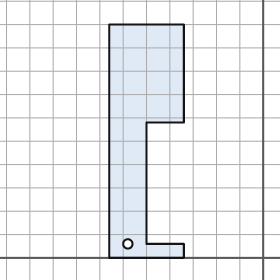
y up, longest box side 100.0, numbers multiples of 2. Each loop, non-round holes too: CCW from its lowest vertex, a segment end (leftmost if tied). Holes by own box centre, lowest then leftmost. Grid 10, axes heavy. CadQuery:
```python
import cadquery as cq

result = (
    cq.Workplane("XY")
    .moveTo(-66.0, 0.0)
    .lineTo(-34.0, 0.0)
    .lineTo(-34.0, 6.0)
    .lineTo(-50.0, 6.0)
    .lineTo(-50.0, 58.0)
    .lineTo(-34.0, 58.0)
    .lineTo(-34.0, 100.0)
    .lineTo(-66.0, 100.0)
    .close()
    .moveTo(-58.0, 6.0)
    .circle(2.0)
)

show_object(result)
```